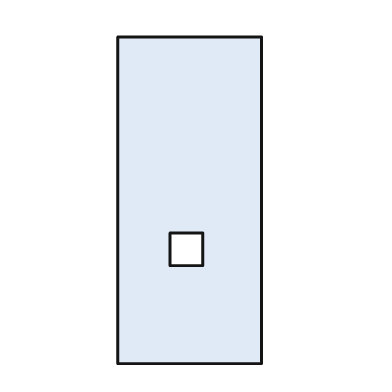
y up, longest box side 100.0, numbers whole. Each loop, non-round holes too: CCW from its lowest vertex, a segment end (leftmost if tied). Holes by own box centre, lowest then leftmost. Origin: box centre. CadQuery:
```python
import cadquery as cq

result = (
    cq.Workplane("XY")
    .moveTo(-22.0, -50.0)
    .lineTo(22.0, -50.0)
    .lineTo(22.0, 50.0)
    .lineTo(-22.0, 50.0)
    .close()
    .moveTo(-6.0, -20.0)
    .lineTo(4.0, -20.0)
    .lineTo(4.0, -10.0)
    .lineTo(-6.0, -10.0)
    .close()
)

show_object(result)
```